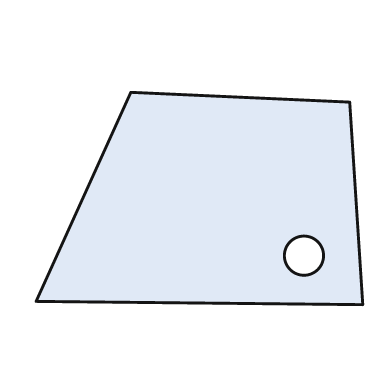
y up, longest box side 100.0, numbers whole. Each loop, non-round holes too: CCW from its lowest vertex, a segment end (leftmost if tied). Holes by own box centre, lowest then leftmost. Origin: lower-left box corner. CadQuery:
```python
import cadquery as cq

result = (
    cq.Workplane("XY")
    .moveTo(100.0, 0.0)
    .lineTo(96.0, 62.0)
    .lineTo(29.0, 65.0)
    .lineTo(0.0, 1.0)
    .close()
    .moveTo(82.0, 15.0)
    .circle(6.0)
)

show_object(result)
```